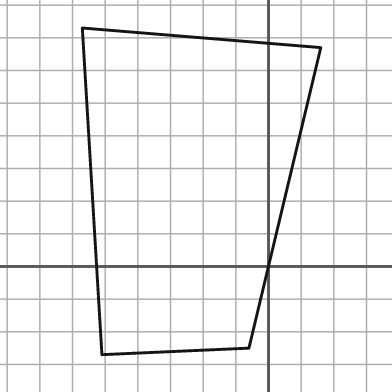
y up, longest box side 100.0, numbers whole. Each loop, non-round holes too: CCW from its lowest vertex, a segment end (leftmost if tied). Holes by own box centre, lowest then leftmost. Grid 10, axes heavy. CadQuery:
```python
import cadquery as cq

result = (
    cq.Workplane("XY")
    .moveTo(-51.0, -27.0)
    .lineTo(-6.0, -25.0)
    .lineTo(16.0, 67.0)
    .lineTo(-57.0, 73.0)
    .close()
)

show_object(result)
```